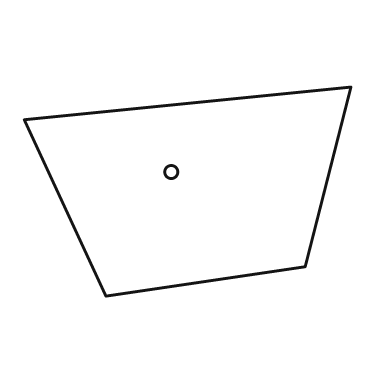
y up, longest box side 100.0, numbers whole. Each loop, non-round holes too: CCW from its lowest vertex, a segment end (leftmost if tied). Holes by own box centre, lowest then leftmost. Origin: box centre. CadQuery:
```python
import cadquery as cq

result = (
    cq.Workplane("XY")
    .moveTo(-25.0, -32.0)
    .lineTo(36.0, -23.0)
    .lineTo(50.0, 32.0)
    .lineTo(-50.0, 22.0)
    .close()
    .moveTo(-5.0, 6.0)
    .circle(2.0)
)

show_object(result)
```